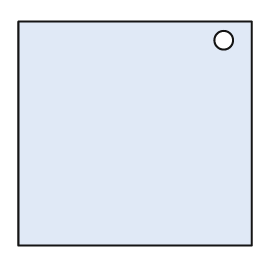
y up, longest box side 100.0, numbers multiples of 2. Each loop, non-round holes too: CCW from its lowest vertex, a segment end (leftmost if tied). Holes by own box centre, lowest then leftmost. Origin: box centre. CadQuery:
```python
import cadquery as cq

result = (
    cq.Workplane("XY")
    .moveTo(-50.0, -48.0)
    .lineTo(50.0, -48.0)
    .lineTo(50.0, 48.0)
    .lineTo(-50.0, 48.0)
    .close()
    .moveTo(38.0, 40.0)
    .circle(4.0)
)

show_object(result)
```